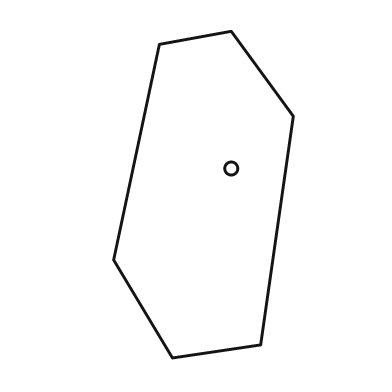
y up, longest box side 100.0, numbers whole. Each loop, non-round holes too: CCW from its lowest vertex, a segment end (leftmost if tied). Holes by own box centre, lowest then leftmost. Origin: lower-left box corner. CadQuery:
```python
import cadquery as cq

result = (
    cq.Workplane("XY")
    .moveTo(18.0, 0.0)
    .lineTo(45.0, 4.0)
    .lineTo(55.0, 74.0)
    .lineTo(36.0, 100.0)
    .lineTo(14.0, 96.0)
    .lineTo(0.0, 30.0)
    .close()
    .moveTo(36.0, 58.0)
    .circle(2.0)
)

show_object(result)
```